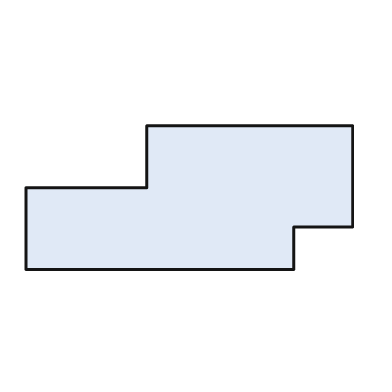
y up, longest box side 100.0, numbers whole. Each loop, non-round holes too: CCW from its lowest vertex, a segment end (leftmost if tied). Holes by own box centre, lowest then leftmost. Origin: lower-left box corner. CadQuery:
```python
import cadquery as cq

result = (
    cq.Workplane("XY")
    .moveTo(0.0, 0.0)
    .lineTo(82.0, 0.0)
    .lineTo(82.0, 13.0)
    .lineTo(100.0, 13.0)
    .lineTo(100.0, 44.0)
    .lineTo(37.0, 44.0)
    .lineTo(37.0, 25.0)
    .lineTo(0.0, 25.0)
    .close()
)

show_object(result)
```